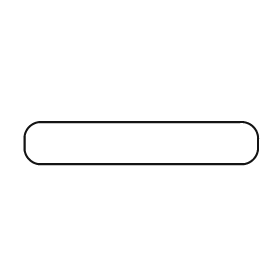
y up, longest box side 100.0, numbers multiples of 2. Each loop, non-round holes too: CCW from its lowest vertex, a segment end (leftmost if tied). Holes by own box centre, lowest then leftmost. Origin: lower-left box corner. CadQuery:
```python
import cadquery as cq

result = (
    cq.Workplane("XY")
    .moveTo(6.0, 0.0)
    .lineTo(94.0, 0.0)
    .threePointArc((98.0, 2.0), (100.0, 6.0))
    .lineTo(100.0, 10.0)
    .threePointArc((98.0, 16.0), (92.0, 18.0))
    .lineTo(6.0, 18.0)
    .threePointArc((2.0, 16.0), (0.0, 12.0))
    .lineTo(0.0, 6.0)
    .threePointArc((2.0, 2.0), (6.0, 0.0))
    .close()
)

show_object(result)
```